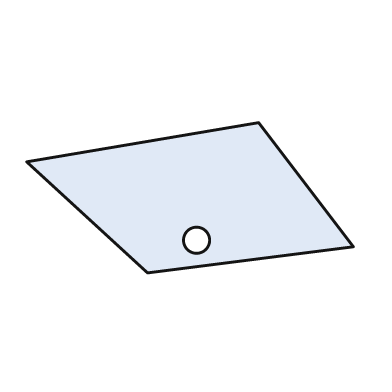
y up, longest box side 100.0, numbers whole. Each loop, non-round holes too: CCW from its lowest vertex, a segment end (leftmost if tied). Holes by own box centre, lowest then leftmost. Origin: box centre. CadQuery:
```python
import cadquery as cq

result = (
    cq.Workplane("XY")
    .moveTo(-13.0, -23.0)
    .lineTo(50.0, -15.0)
    .lineTo(21.0, 23.0)
    .lineTo(-50.0, 11.0)
    .close()
    .moveTo(2.0, -13.0)
    .circle(4.0)
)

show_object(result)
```